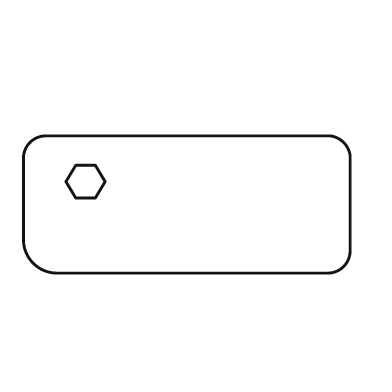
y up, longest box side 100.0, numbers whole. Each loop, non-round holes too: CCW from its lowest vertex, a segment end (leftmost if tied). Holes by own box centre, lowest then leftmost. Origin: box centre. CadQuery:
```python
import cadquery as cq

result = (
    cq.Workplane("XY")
    .moveTo(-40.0, -21.0)
    .lineTo(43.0, -21.0)
    .threePointArc((48.0, -19.0), (50.0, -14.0))
    .lineTo(50.0, 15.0)
    .threePointArc((48.0, 19.0), (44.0, 21.0))
    .lineTo(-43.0, 21.0)
    .threePointArc((-48.0, 19.0), (-50.0, 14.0))
    .lineTo(-50.0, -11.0)
    .threePointArc((-47.0, -18.0), (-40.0, -21.0))
    .close()
    .moveTo(-34.0, 2.0)
    .lineTo(-28.0, 2.0)
    .lineTo(-25.0, 7.0)
    .lineTo(-28.0, 12.0)
    .lineTo(-34.0, 12.0)
    .lineTo(-37.0, 7.0)
    .close()
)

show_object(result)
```